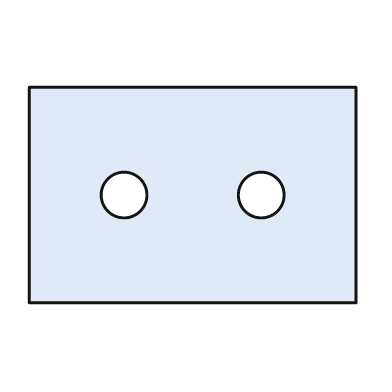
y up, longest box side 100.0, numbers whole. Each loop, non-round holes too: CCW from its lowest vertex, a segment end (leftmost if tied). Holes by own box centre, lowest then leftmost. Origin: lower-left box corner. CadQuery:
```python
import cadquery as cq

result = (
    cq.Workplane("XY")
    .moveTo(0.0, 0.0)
    .lineTo(100.0, 0.0)
    .lineTo(100.0, 66.0)
    .lineTo(0.0, 66.0)
    .close()
    .moveTo(29.0, 33.0)
    .circle(7.0)
    .moveTo(71.0, 33.0)
    .circle(7.0)
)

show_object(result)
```